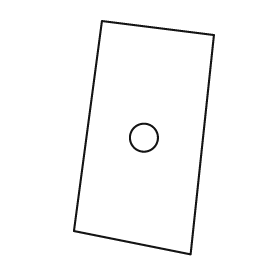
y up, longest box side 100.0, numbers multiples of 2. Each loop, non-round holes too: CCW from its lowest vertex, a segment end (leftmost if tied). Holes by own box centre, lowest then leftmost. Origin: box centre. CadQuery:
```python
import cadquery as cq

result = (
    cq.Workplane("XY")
    .moveTo(20.0, -50.0)
    .lineTo(30.0, 44.0)
    .lineTo(-18.0, 50.0)
    .lineTo(-30.0, -40.0)
    .close()
    .moveTo(0.0, 0.0)
    .circle(6.0)
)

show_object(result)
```